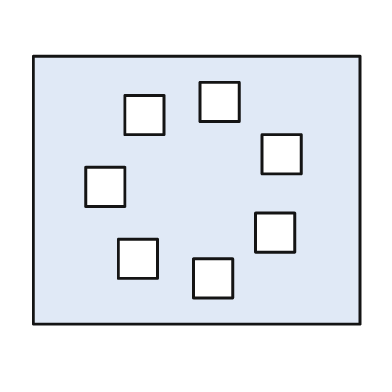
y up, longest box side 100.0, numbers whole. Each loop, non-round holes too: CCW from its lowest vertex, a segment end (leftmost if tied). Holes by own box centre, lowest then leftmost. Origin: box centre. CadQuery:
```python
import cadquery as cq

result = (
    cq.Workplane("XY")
    .moveTo(-50.0, -41.0)
    .lineTo(50.0, -41.0)
    .lineTo(50.0, 41.0)
    .lineTo(-50.0, 41.0)
    .close()
    .moveTo(-1.0, -33.0)
    .lineTo(11.0, -33.0)
    .lineTo(11.0, -21.0)
    .lineTo(-1.0, -21.0)
    .close()
    .moveTo(-24.0, -27.0)
    .lineTo(-12.0, -27.0)
    .lineTo(-12.0, -15.0)
    .lineTo(-24.0, -15.0)
    .close()
    .moveTo(18.0, -19.0)
    .lineTo(30.0, -19.0)
    .lineTo(30.0, -7.0)
    .lineTo(18.0, -7.0)
    .close()
    .moveTo(-34.0, -5.0)
    .lineTo(-22.0, -5.0)
    .lineTo(-22.0, 7.0)
    .lineTo(-34.0, 7.0)
    .close()
    .moveTo(20.0, 5.0)
    .lineTo(32.0, 5.0)
    .lineTo(32.0, 17.0)
    .lineTo(20.0, 17.0)
    .close()
    .moveTo(-22.0, 17.0)
    .lineTo(-10.0, 17.0)
    .lineTo(-10.0, 29.0)
    .lineTo(-22.0, 29.0)
    .close()
    .moveTo(1.0, 21.0)
    .lineTo(13.0, 21.0)
    .lineTo(13.0, 33.0)
    .lineTo(1.0, 33.0)
    .close()
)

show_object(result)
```